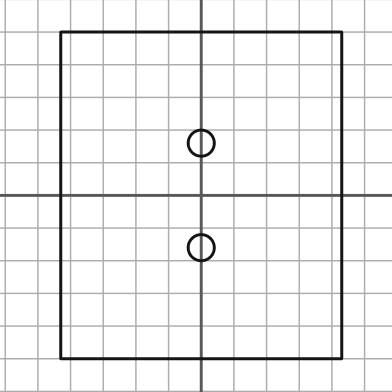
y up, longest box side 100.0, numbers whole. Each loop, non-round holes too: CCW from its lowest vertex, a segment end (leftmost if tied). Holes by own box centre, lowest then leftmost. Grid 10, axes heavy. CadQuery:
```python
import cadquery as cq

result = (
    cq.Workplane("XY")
    .moveTo(-43.0, -50.0)
    .lineTo(43.0, -50.0)
    .lineTo(43.0, 50.0)
    .lineTo(-43.0, 50.0)
    .close()
    .moveTo(0.0, -16.0)
    .circle(4.0)
    .moveTo(0.0, 16.0)
    .circle(4.0)
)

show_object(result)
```